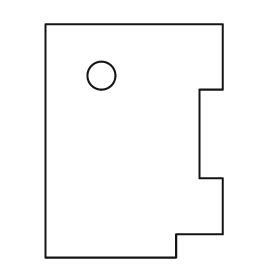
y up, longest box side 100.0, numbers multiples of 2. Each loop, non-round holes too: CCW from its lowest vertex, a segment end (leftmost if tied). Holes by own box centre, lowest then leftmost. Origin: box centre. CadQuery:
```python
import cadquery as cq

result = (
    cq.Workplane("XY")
    .moveTo(-38.0, -50.0)
    .lineTo(18.0, -50.0)
    .lineTo(18.0, -40.0)
    .lineTo(38.0, -40.0)
    .lineTo(38.0, -16.0)
    .lineTo(28.0, -16.0)
    .lineTo(28.0, 22.0)
    .lineTo(38.0, 22.0)
    .lineTo(38.0, 50.0)
    .lineTo(-38.0, 50.0)
    .close()
    .moveTo(-14.0, 28.0)
    .circle(6.0)
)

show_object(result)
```